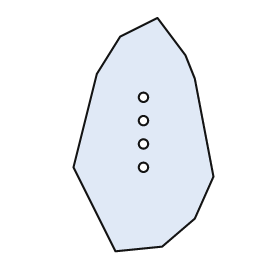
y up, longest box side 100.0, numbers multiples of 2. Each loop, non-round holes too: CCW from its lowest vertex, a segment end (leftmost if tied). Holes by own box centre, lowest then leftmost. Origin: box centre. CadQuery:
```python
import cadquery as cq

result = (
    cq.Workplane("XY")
    .moveTo(-12.0, -50.0)
    .lineTo(8.0, -48.0)
    .lineTo(22.0, -36.0)
    .lineTo(30.0, -18.0)
    .lineTo(22.0, 24.0)
    .lineTo(18.0, 34.0)
    .lineTo(6.0, 50.0)
    .lineTo(-10.0, 42.0)
    .lineTo(-20.0, 26.0)
    .lineTo(-30.0, -14.0)
    .close()
    .moveTo(0.0, -14.0)
    .circle(2.0)
    .moveTo(0.0, -4.0)
    .circle(2.0)
    .moveTo(0.0, 6.0)
    .circle(2.0)
    .moveTo(0.0, 16.0)
    .circle(2.0)
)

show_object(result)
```